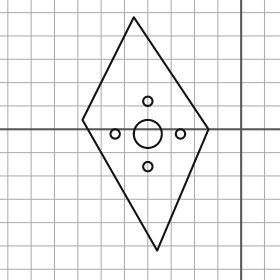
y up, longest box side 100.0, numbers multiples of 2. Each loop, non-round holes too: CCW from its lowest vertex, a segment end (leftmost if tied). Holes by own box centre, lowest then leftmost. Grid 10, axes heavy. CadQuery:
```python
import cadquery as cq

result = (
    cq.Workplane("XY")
    .moveTo(-36.0, -52.0)
    .lineTo(-14.0, 0.0)
    .lineTo(-46.0, 48.0)
    .lineTo(-68.0, 4.0)
    .close()
    .moveTo(-40.0, -16.0)
    .circle(2.0)
    .moveTo(-54.0, -2.0)
    .circle(2.0)
    .moveTo(-40.0, -2.0)
    .circle(6.0)
    .moveTo(-26.0, -2.0)
    .circle(2.0)
    .moveTo(-40.0, 12.0)
    .circle(2.0)
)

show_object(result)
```